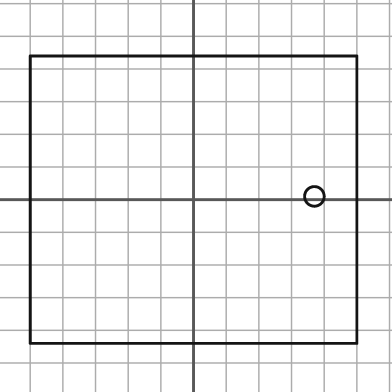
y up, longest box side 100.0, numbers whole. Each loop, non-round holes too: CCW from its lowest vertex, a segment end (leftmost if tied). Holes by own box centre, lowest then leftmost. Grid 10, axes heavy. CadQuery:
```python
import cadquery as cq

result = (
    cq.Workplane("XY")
    .moveTo(-50.0, -44.0)
    .lineTo(50.0, -44.0)
    .lineTo(50.0, 44.0)
    .lineTo(-50.0, 44.0)
    .close()
    .moveTo(37.0, 1.0)
    .circle(3.0)
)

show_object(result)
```